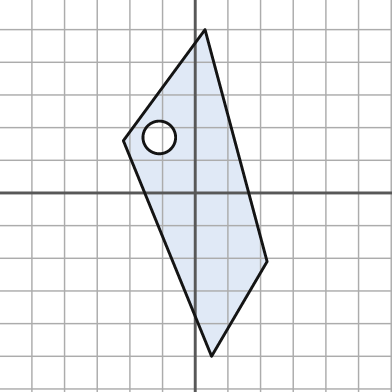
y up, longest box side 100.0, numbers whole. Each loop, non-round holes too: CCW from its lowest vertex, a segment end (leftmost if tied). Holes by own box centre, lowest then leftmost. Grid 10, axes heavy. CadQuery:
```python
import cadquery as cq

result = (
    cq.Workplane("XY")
    .moveTo(5.0, -50.0)
    .lineTo(22.0, -21.0)
    .lineTo(3.0, 50.0)
    .lineTo(-22.0, 16.0)
    .close()
    .moveTo(-11.0, 17.0)
    .circle(5.0)
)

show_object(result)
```